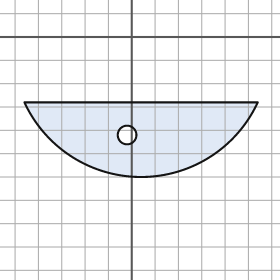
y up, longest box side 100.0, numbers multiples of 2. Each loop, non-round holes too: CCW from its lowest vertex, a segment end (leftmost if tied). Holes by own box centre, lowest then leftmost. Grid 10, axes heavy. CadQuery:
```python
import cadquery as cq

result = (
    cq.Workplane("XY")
    .moveTo(-46.0, -28.0)
    .threePointArc((4.0, -60.0), (54.0, -28.0))
    .close()
    .moveTo(-2.0, -42.0)
    .circle(4.0)
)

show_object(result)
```